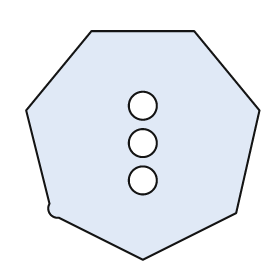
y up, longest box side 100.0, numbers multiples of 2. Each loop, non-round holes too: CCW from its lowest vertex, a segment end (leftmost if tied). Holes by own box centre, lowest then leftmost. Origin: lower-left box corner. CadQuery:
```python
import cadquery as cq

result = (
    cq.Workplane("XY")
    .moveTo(50.0, 0.0)
    .lineTo(90.0, 20.0)
    .lineTo(100.0, 64.0)
    .lineTo(72.0, 98.0)
    .lineTo(28.0, 98.0)
    .lineTo(0.0, 64.0)
    .lineTo(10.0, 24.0)
    .threePointArc((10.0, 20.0), (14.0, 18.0))
    .close()
    .moveTo(50.0, 34.0)
    .circle(6.0)
    .moveTo(50.0, 50.0)
    .circle(6.0)
    .moveTo(50.0, 66.0)
    .circle(6.0)
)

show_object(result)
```